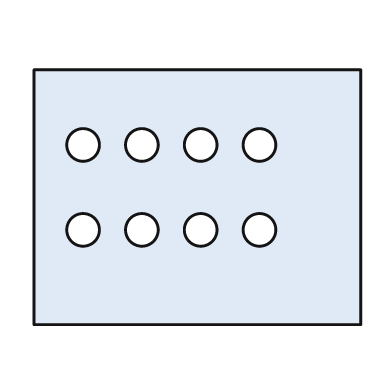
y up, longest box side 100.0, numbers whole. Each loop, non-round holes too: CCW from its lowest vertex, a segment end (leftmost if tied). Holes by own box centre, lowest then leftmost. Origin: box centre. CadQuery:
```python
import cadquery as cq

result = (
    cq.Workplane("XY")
    .moveTo(-50.0, -39.0)
    .lineTo(50.0, -39.0)
    .lineTo(50.0, 39.0)
    .lineTo(-50.0, 39.0)
    .close()
    .moveTo(-35.0, -10.0)
    .circle(5.0)
    .moveTo(-17.0, -10.0)
    .circle(5.0)
    .moveTo(1.0, -10.0)
    .circle(5.0)
    .moveTo(19.0, -10.0)
    .circle(5.0)
    .moveTo(-35.0, 16.0)
    .circle(5.0)
    .moveTo(-17.0, 16.0)
    .circle(5.0)
    .moveTo(1.0, 16.0)
    .circle(5.0)
    .moveTo(19.0, 16.0)
    .circle(5.0)
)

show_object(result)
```